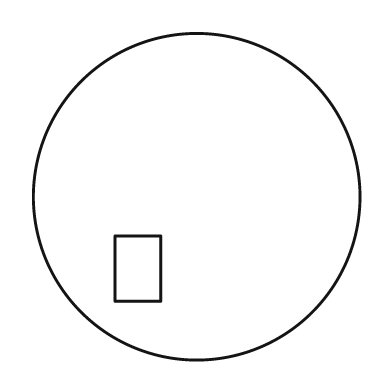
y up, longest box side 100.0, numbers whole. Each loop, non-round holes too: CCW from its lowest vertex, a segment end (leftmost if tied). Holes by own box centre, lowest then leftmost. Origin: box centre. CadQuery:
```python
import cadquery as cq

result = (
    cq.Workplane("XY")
    .moveTo(0.0, 0.0)
    .circle(50.0)
    .moveTo(-25.0, -32.0)
    .lineTo(-11.0, -32.0)
    .lineTo(-11.0, -12.0)
    .lineTo(-25.0, -12.0)
    .close()
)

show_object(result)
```